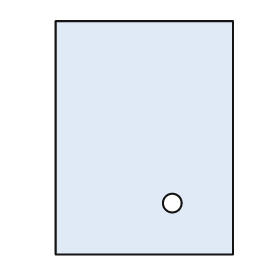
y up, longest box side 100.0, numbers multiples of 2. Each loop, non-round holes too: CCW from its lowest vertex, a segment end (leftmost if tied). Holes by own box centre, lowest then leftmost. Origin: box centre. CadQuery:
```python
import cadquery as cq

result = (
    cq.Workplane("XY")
    .moveTo(-38.0, -50.0)
    .lineTo(38.0, -50.0)
    .lineTo(38.0, 50.0)
    .lineTo(-38.0, 50.0)
    .close()
    .moveTo(12.0, -28.0)
    .circle(4.0)
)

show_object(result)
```